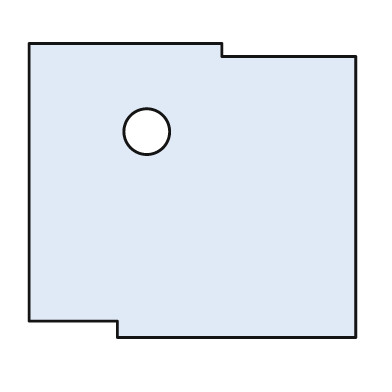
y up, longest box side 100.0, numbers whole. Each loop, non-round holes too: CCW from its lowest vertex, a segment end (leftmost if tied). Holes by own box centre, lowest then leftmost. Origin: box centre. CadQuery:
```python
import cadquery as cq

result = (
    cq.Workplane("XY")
    .moveTo(-23.0, -45.0)
    .lineTo(50.0, -45.0)
    .lineTo(50.0, 41.0)
    .lineTo(9.0, 41.0)
    .lineTo(9.0, 45.0)
    .lineTo(-50.0, 45.0)
    .lineTo(-50.0, -40.0)
    .lineTo(-23.0, -40.0)
    .close()
    .moveTo(-14.0, 18.0)
    .circle(7.0)
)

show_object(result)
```